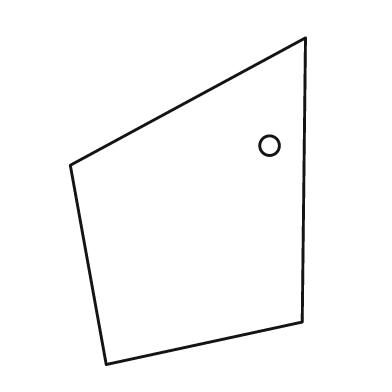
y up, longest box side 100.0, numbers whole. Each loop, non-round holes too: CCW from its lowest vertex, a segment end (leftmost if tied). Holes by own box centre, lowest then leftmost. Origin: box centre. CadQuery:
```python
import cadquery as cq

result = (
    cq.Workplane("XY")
    .moveTo(-25.0, -50.0)
    .lineTo(35.0, -37.0)
    .lineTo(36.0, 50.0)
    .lineTo(-36.0, 11.0)
    .close()
    .moveTo(25.0, 17.0)
    .circle(3.0)
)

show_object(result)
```